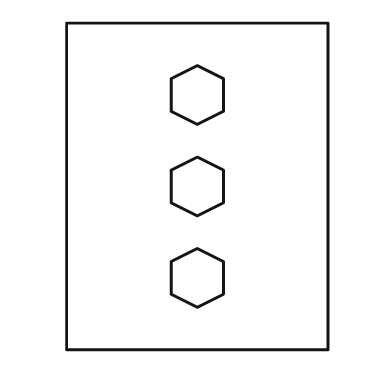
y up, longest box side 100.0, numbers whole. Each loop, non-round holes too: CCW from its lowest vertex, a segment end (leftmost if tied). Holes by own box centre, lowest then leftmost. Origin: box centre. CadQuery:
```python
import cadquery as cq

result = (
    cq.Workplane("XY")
    .moveTo(-40.0, -50.0)
    .lineTo(40.0, -50.0)
    .lineTo(40.0, 50.0)
    .lineTo(-40.0, 50.0)
    .close()
    .moveTo(0.0, -37.0)
    .lineTo(8.0, -33.0)
    .lineTo(8.0, -23.0)
    .lineTo(0.0, -19.0)
    .lineTo(-8.0, -23.0)
    .lineTo(-8.0, -33.0)
    .close()
    .moveTo(0.0, -9.0)
    .lineTo(8.0, -5.0)
    .lineTo(8.0, 5.0)
    .lineTo(0.0, 9.0)
    .lineTo(-8.0, 5.0)
    .lineTo(-8.0, -5.0)
    .close()
    .moveTo(0.0, 19.0)
    .lineTo(8.0, 23.0)
    .lineTo(8.0, 33.0)
    .lineTo(0.0, 37.0)
    .lineTo(-8.0, 33.0)
    .lineTo(-8.0, 23.0)
    .close()
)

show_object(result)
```